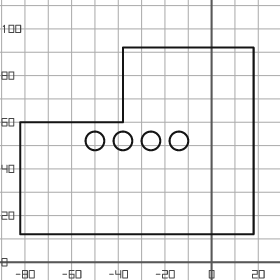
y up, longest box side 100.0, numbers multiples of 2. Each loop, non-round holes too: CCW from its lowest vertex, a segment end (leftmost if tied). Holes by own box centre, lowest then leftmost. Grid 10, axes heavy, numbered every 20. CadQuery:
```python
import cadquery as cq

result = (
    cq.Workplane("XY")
    .moveTo(-82.0, 12.0)
    .lineTo(18.0, 12.0)
    .lineTo(18.0, 92.0)
    .lineTo(-38.0, 92.0)
    .lineTo(-38.0, 60.0)
    .lineTo(-82.0, 60.0)
    .close()
    .moveTo(-50.0, 52.0)
    .circle(4.0)
    .moveTo(-38.0, 52.0)
    .circle(4.0)
    .moveTo(-26.0, 52.0)
    .circle(4.0)
    .moveTo(-14.0, 52.0)
    .circle(4.0)
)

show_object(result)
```